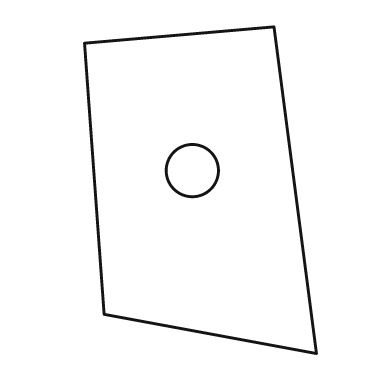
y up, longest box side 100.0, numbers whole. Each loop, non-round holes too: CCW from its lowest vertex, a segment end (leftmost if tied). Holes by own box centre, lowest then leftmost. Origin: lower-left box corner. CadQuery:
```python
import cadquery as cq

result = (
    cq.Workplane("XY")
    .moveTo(71.0, 0.0)
    .lineTo(58.0, 100.0)
    .lineTo(0.0, 95.0)
    .lineTo(6.0, 12.0)
    .close()
    .moveTo(33.0, 56.0)
    .circle(8.0)
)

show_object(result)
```